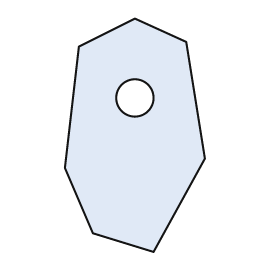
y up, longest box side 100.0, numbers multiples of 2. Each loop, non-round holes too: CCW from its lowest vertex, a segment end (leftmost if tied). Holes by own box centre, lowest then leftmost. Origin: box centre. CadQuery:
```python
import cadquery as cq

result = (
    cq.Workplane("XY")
    .moveTo(8.0, -50.0)
    .lineTo(30.0, -10.0)
    .lineTo(22.0, 40.0)
    .lineTo(0.0, 50.0)
    .lineTo(-24.0, 38.0)
    .lineTo(-30.0, -14.0)
    .lineTo(-18.0, -42.0)
    .close()
    .moveTo(0.0, 16.0)
    .circle(8.0)
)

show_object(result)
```